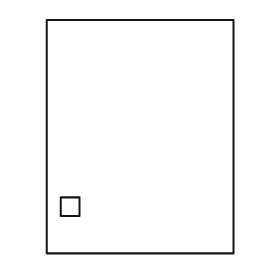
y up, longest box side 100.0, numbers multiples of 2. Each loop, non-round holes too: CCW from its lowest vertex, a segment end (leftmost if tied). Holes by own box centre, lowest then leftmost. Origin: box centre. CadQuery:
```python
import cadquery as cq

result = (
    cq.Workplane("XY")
    .moveTo(-40.0, -50.0)
    .lineTo(40.0, -50.0)
    .lineTo(40.0, 50.0)
    .lineTo(-40.0, 50.0)
    .close()
    .moveTo(-34.0, -34.0)
    .lineTo(-26.0, -34.0)
    .lineTo(-26.0, -26.0)
    .lineTo(-34.0, -26.0)
    .close()
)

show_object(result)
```